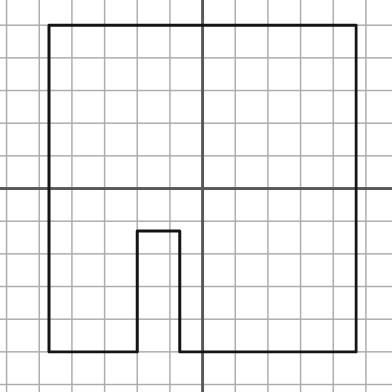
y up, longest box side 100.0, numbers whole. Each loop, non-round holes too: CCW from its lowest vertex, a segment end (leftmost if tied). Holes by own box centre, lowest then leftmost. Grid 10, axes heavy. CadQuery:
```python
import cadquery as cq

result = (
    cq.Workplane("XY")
    .moveTo(-47.0, -50.0)
    .lineTo(-20.0, -50.0)
    .lineTo(-20.0, -13.0)
    .lineTo(-7.0, -13.0)
    .lineTo(-7.0, -50.0)
    .lineTo(47.0, -50.0)
    .lineTo(47.0, 50.0)
    .lineTo(-47.0, 50.0)
    .close()
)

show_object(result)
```